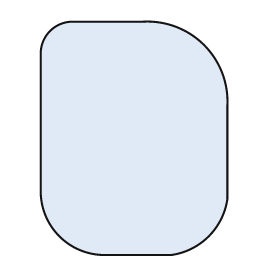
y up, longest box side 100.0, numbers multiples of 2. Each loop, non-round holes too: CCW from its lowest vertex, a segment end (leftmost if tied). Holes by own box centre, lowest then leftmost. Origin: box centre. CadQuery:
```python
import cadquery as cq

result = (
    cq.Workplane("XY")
    .moveTo(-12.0, -50.0)
    .lineTo(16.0, -50.0)
    .threePointArc((32.0, -42.0), (40.0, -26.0))
    .lineTo(40.0, 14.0)
    .threePointArc((30.0, 40.0), (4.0, 50.0))
    .lineTo(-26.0, 50.0)
    .threePointArc((-36.0, 46.0), (-40.0, 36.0))
    .lineTo(-40.0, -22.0)
    .threePointArc((-32.0, -42.0), (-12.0, -50.0))
    .close()
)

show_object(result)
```